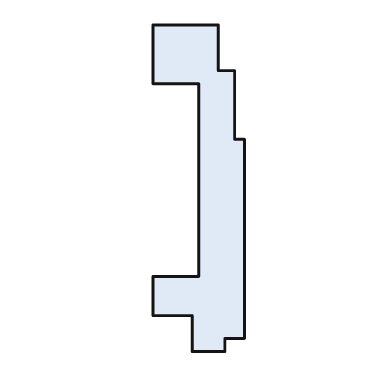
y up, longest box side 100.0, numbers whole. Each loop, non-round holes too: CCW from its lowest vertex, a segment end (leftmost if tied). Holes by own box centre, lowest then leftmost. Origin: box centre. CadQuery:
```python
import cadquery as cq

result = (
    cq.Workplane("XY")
    .moveTo(-2.0, -50.0)
    .lineTo(8.0, -50.0)
    .lineTo(8.0, -46.0)
    .lineTo(14.0, -46.0)
    .lineTo(14.0, 15.0)
    .lineTo(11.0, 15.0)
    .lineTo(11.0, 36.0)
    .lineTo(6.0, 36.0)
    .lineTo(6.0, 50.0)
    .lineTo(-14.0, 50.0)
    .lineTo(-14.0, 32.0)
    .lineTo(0.0, 32.0)
    .lineTo(0.0, -27.0)
    .lineTo(-14.0, -27.0)
    .lineTo(-14.0, -39.0)
    .lineTo(-2.0, -39.0)
    .close()
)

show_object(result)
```